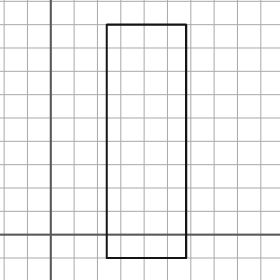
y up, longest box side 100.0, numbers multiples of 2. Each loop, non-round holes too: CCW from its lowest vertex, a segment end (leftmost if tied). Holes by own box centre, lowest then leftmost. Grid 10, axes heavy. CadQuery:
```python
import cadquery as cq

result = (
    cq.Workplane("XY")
    .moveTo(24.0, -10.0)
    .lineTo(58.0, -10.0)
    .lineTo(58.0, 90.0)
    .lineTo(24.0, 90.0)
    .close()
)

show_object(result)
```